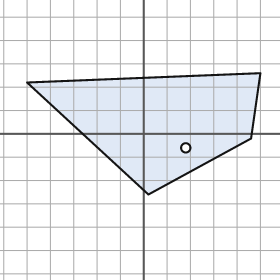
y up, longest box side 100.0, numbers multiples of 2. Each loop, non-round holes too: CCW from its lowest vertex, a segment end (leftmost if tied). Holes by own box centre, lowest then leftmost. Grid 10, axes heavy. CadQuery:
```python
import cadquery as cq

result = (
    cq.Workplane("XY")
    .moveTo(2.0, -26.0)
    .lineTo(46.0, -2.0)
    .lineTo(50.0, 26.0)
    .lineTo(-50.0, 22.0)
    .close()
    .moveTo(18.0, -6.0)
    .circle(2.0)
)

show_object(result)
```